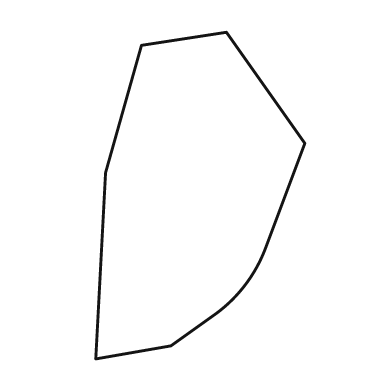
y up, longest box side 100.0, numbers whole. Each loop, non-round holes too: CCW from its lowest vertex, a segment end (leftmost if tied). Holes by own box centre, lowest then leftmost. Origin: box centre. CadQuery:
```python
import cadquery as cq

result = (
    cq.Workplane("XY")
    .moveTo(-32.0, -50.0)
    .lineTo(-9.0, -46.0)
    .lineTo(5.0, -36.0)
    .threePointArc((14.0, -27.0), (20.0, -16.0))
    .lineTo(32.0, 16.0)
    .lineTo(8.0, 50.0)
    .lineTo(-18.0, 46.0)
    .lineTo(-29.0, 7.0)
    .close()
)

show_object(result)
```